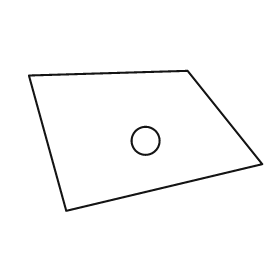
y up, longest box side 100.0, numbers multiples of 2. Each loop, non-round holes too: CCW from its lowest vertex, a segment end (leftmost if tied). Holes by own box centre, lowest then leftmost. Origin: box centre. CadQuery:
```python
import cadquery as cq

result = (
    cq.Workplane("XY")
    .moveTo(-34.0, -30.0)
    .lineTo(50.0, -10.0)
    .lineTo(18.0, 30.0)
    .lineTo(-50.0, 28.0)
    .close()
    .moveTo(0.0, 0.0)
    .circle(6.0)
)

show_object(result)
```